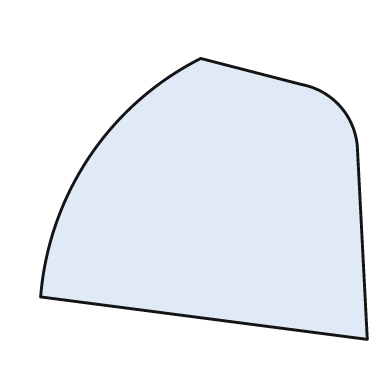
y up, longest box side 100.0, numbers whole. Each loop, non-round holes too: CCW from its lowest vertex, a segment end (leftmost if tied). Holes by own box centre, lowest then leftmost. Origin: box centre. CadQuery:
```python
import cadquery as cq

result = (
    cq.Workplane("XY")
    .moveTo(50.0, -43.0)
    .lineTo(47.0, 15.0)
    .threePointArc((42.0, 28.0), (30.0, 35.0))
    .lineTo(-1.0, 43.0)
    .threePointArc((-35.0, 13.0), (-50.0, -30.0))
    .close()
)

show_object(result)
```